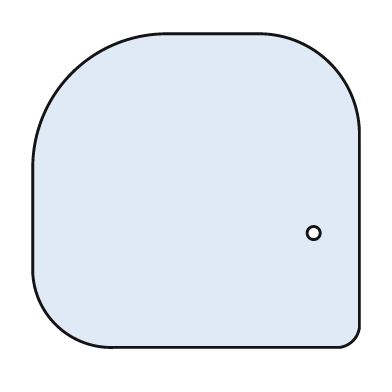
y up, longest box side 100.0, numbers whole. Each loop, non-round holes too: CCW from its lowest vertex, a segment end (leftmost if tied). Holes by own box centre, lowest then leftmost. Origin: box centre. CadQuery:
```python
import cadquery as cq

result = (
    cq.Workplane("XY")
    .moveTo(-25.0, -48.0)
    .lineTo(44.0, -48.0)
    .threePointArc((48.0, -46.0), (50.0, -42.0))
    .lineTo(50.0, 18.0)
    .threePointArc((41.0, 39.0), (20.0, 48.0))
    .lineTo(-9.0, 48.0)
    .threePointArc((-38.0, 36.0), (-50.0, 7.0))
    .lineTo(-50.0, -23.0)
    .threePointArc((-43.0, -41.0), (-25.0, -48.0))
    .close()
    .moveTo(36.0, -13.0)
    .circle(2.0)
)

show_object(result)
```